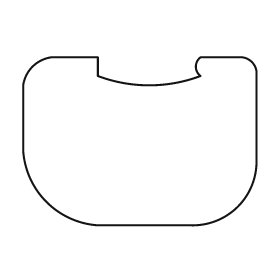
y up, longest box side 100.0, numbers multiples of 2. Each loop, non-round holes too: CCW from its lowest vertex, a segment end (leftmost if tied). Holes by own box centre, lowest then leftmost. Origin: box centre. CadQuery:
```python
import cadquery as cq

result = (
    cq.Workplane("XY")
    .moveTo(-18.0, -36.0)
    .lineTo(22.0, -36.0)
    .threePointArc((42.0, -28.0), (50.0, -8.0))
    .lineTo(50.0, 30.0)
    .threePointArc((48.0, 34.0), (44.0, 36.0))
    .lineTo(26.0, 36.0)
    .threePointArc((24.0, 32.0), (26.0, 28.0))
    .threePointArc((4.0, 24.0), (-18.0, 28.0))
    .lineTo(-18.0, 36.0)
    .lineTo(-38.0, 36.0)
    .threePointArc((-46.0, 32.0), (-50.0, 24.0))
    .lineTo(-50.0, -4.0)
    .threePointArc((-40.0, -26.0), (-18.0, -36.0))
    .close()
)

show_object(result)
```